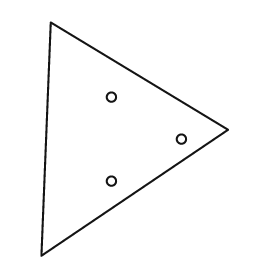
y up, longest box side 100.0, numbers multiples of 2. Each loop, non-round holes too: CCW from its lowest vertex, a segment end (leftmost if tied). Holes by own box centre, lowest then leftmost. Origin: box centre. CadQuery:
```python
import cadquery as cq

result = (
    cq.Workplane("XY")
    .moveTo(-40.0, -50.0)
    .lineTo(40.0, 4.0)
    .lineTo(-36.0, 50.0)
    .close()
    .moveTo(-10.0, -18.0)
    .circle(2.0)
    .moveTo(20.0, 0.0)
    .circle(2.0)
    .moveTo(-10.0, 18.0)
    .circle(2.0)
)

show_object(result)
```